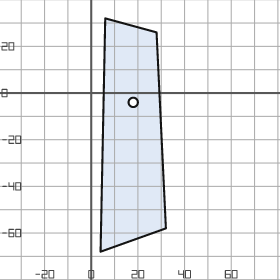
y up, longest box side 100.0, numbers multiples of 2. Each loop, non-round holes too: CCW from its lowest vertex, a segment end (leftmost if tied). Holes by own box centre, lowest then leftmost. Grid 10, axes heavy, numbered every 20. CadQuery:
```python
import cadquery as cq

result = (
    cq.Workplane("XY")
    .moveTo(4.0, -68.0)
    .lineTo(32.0, -58.0)
    .lineTo(28.0, 26.0)
    .lineTo(6.0, 32.0)
    .close()
    .moveTo(18.0, -4.0)
    .circle(2.0)
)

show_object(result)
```